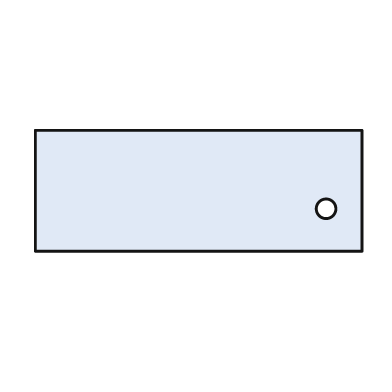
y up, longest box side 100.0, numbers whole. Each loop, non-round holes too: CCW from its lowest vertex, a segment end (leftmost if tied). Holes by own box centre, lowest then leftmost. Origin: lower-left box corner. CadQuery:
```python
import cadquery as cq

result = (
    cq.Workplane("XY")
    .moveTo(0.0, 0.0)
    .lineTo(100.0, 0.0)
    .lineTo(100.0, 37.0)
    .lineTo(0.0, 37.0)
    .close()
    .moveTo(89.0, 13.0)
    .circle(3.0)
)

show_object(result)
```